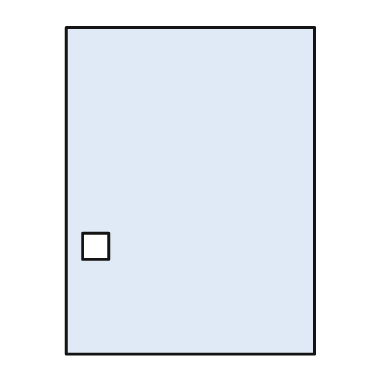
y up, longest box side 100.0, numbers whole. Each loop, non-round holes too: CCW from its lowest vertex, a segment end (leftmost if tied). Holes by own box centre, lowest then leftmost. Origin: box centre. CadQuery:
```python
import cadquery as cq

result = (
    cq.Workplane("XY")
    .moveTo(-38.0, -50.0)
    .lineTo(38.0, -50.0)
    .lineTo(38.0, 50.0)
    .lineTo(-38.0, 50.0)
    .close()
    .moveTo(-33.0, -21.0)
    .lineTo(-25.0, -21.0)
    .lineTo(-25.0, -13.0)
    .lineTo(-33.0, -13.0)
    .close()
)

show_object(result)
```